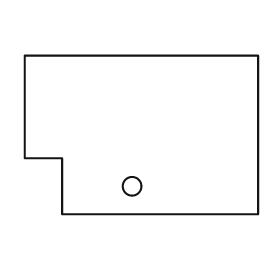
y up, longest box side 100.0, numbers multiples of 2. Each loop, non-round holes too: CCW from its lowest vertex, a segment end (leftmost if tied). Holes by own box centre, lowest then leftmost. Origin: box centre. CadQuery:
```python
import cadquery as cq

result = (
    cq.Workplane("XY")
    .moveTo(-34.0, -34.0)
    .lineTo(50.0, -34.0)
    .lineTo(50.0, 34.0)
    .lineTo(-50.0, 34.0)
    .lineTo(-50.0, -10.0)
    .lineTo(-34.0, -10.0)
    .close()
    .moveTo(-4.0, -22.0)
    .circle(4.0)
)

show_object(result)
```